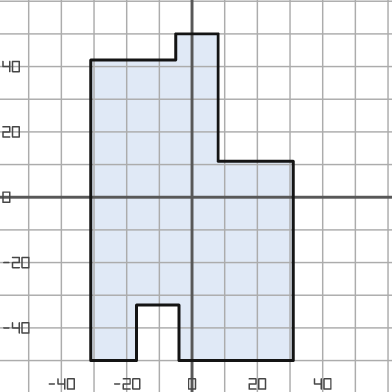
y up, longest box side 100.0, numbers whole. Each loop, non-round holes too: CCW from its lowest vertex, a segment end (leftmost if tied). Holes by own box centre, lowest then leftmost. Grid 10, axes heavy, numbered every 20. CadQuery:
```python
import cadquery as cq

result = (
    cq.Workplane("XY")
    .moveTo(-31.0, -50.0)
    .lineTo(-17.0, -50.0)
    .lineTo(-17.0, -33.0)
    .lineTo(-4.0, -33.0)
    .lineTo(-4.0, -50.0)
    .lineTo(31.0, -50.0)
    .lineTo(31.0, 11.0)
    .lineTo(8.0, 11.0)
    .lineTo(8.0, 50.0)
    .lineTo(-5.0, 50.0)
    .lineTo(-5.0, 42.0)
    .lineTo(-31.0, 42.0)
    .close()
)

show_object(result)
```